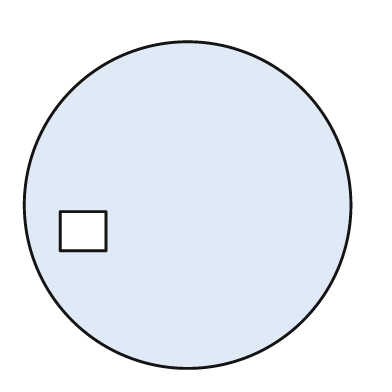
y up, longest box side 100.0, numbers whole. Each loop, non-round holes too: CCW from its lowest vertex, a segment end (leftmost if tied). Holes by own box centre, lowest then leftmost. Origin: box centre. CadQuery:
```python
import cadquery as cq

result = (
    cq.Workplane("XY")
    .moveTo(0.0, 0.0)
    .circle(50.0)
    .moveTo(-39.0, -14.0)
    .lineTo(-25.0, -14.0)
    .lineTo(-25.0, -2.0)
    .lineTo(-39.0, -2.0)
    .close()
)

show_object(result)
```